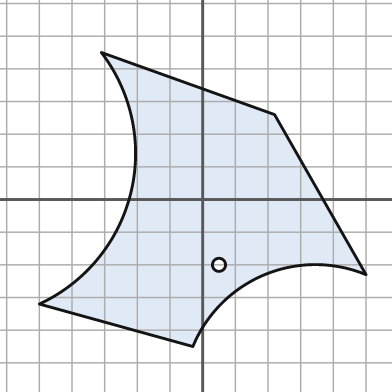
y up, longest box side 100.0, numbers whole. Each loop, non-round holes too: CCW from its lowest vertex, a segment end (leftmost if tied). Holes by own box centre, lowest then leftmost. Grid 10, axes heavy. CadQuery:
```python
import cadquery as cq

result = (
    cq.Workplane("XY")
    .moveTo(-3.0, -45.0)
    .threePointArc((19.0, -23.0), (50.0, -23.0))
    .lineTo(22.0, 26.0)
    .lineTo(-31.0, 45.0)
    .threePointArc((-22.0, 2.0), (-50.0, -32.0))
    .close()
    .moveTo(5.0, -20.0)
    .circle(2.0)
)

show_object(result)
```